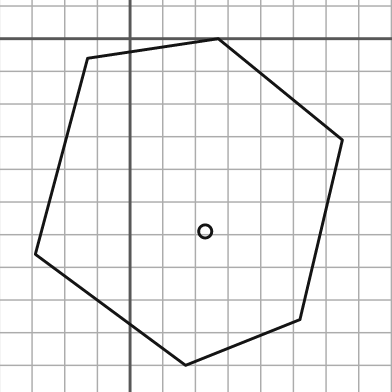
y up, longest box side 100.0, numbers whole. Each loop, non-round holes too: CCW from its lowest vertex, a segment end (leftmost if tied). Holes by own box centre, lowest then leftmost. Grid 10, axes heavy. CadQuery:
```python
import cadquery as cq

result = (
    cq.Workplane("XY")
    .moveTo(17.0, -100.0)
    .lineTo(52.0, -86.0)
    .lineTo(65.0, -31.0)
    .lineTo(27.0, 0.0)
    .lineTo(-13.0, -6.0)
    .lineTo(-29.0, -66.0)
    .close()
    .moveTo(23.0, -59.0)
    .circle(2.0)
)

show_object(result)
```